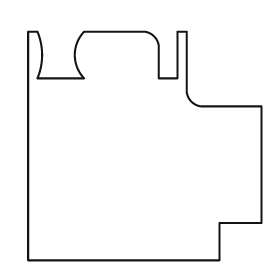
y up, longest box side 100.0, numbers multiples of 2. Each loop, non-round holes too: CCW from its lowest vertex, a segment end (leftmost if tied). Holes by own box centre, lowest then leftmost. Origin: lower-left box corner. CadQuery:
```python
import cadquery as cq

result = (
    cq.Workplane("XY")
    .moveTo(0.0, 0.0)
    .lineTo(82.0, 0.0)
    .lineTo(82.0, 16.0)
    .lineTo(100.0, 16.0)
    .lineTo(100.0, 66.0)
    .lineTo(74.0, 66.0)
    .threePointArc((70.0, 68.0), (68.0, 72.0))
    .lineTo(68.0, 98.0)
    .lineTo(64.0, 98.0)
    .lineTo(64.0, 78.0)
    .lineTo(56.0, 78.0)
    .lineTo(56.0, 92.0)
    .threePointArc((54.0, 96.0), (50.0, 98.0))
    .lineTo(24.0, 98.0)
    .threePointArc((20.0, 88.0), (24.0, 78.0))
    .lineTo(4.0, 78.0)
    .threePointArc((6.0, 88.0), (4.0, 98.0))
    .lineTo(0.0, 98.0)
    .close()
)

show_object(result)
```